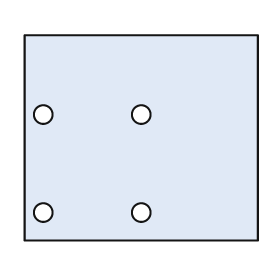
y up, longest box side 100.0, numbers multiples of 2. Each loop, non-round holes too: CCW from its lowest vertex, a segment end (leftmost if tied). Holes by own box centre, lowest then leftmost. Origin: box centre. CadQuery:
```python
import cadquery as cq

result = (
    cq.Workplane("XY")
    .moveTo(-50.0, -44.0)
    .lineTo(50.0, -44.0)
    .lineTo(50.0, 44.0)
    .lineTo(-50.0, 44.0)
    .close()
    .moveTo(-42.0, -32.0)
    .circle(4.0)
    .moveTo(0.0, -32.0)
    .circle(4.0)
    .moveTo(-42.0, 10.0)
    .circle(4.0)
    .moveTo(0.0, 10.0)
    .circle(4.0)
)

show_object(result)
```